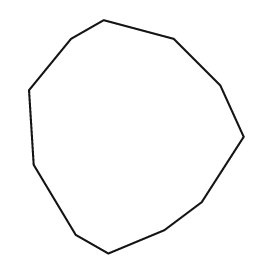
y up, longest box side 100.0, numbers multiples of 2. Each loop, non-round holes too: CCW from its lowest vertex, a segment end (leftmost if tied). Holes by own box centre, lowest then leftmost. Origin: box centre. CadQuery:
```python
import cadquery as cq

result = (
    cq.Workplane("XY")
    .moveTo(-12.0, -50.0)
    .lineTo(12.0, -40.0)
    .lineTo(28.0, -28.0)
    .lineTo(46.0, 0.0)
    .lineTo(36.0, 22.0)
    .lineTo(16.0, 42.0)
    .lineTo(-14.0, 50.0)
    .lineTo(-28.0, 42.0)
    .lineTo(-46.0, 20.0)
    .lineTo(-44.0, -12.0)
    .lineTo(-26.0, -42.0)
    .close()
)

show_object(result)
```